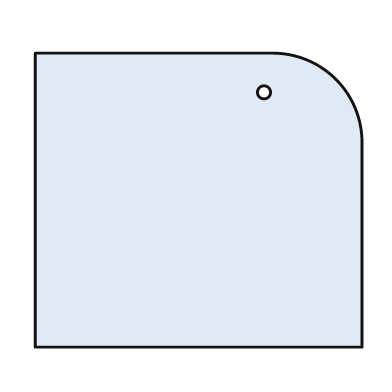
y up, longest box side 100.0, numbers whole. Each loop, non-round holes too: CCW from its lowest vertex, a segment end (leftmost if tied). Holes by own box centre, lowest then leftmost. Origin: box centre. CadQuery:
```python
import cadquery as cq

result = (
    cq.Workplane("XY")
    .moveTo(-50.0, -45.0)
    .lineTo(50.0, -45.0)
    .lineTo(50.0, 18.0)
    .threePointArc((42.0, 37.0), (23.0, 45.0))
    .lineTo(-50.0, 45.0)
    .close()
    .moveTo(20.0, 33.0)
    .circle(2.0)
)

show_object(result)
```